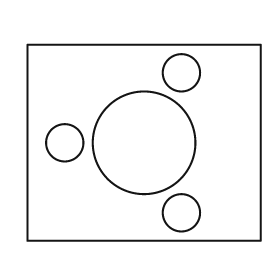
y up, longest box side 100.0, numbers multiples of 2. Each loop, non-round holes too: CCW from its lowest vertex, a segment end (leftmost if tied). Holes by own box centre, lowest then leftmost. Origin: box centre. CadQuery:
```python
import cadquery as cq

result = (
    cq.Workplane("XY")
    .moveTo(-50.0, -42.0)
    .lineTo(50.0, -42.0)
    .lineTo(50.0, 42.0)
    .lineTo(-50.0, 42.0)
    .close()
    .moveTo(16.0, -30.0)
    .circle(8.0)
    .moveTo(-34.0, 0.0)
    .circle(8.0)
    .moveTo(0.0, 0.0)
    .circle(22.0)
    .moveTo(16.0, 30.0)
    .circle(8.0)
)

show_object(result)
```